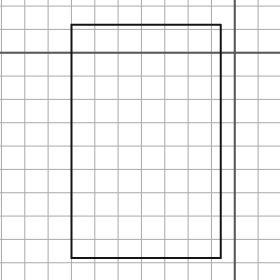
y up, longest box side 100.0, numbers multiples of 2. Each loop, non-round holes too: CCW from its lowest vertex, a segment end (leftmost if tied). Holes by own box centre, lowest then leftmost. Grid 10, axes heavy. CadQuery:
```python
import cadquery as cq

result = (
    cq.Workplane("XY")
    .moveTo(-70.0, -88.0)
    .lineTo(-6.0, -88.0)
    .lineTo(-6.0, 12.0)
    .lineTo(-70.0, 12.0)
    .close()
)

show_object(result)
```